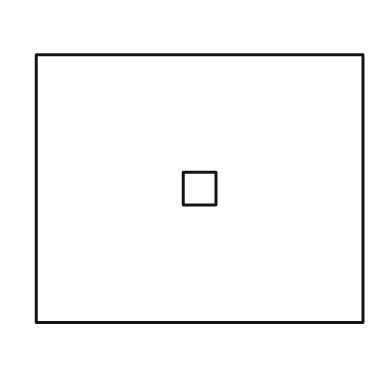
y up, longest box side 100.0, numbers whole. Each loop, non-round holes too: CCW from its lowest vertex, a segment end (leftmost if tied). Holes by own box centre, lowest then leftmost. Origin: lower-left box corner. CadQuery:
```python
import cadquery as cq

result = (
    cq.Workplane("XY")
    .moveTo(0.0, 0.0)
    .lineTo(100.0, 0.0)
    .lineTo(100.0, 82.0)
    .lineTo(0.0, 82.0)
    .close()
    .moveTo(45.0, 36.0)
    .lineTo(55.0, 36.0)
    .lineTo(55.0, 46.0)
    .lineTo(45.0, 46.0)
    .close()
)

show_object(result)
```